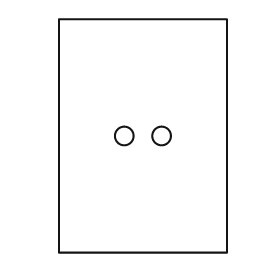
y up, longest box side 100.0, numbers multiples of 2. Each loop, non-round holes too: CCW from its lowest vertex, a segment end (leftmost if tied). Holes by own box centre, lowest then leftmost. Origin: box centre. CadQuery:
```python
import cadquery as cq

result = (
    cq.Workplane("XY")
    .moveTo(-36.0, -50.0)
    .lineTo(36.0, -50.0)
    .lineTo(36.0, 50.0)
    .lineTo(-36.0, 50.0)
    .close()
    .moveTo(-8.0, 0.0)
    .circle(4.0)
    .moveTo(8.0, 0.0)
    .circle(4.0)
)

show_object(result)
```